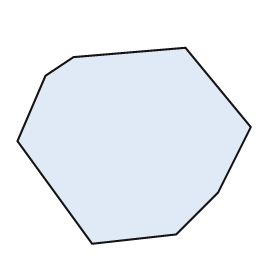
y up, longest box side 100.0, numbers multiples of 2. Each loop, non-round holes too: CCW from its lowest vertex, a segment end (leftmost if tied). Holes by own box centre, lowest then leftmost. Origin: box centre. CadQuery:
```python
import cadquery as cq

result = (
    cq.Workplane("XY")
    .moveTo(-18.0, -42.0)
    .lineTo(18.0, -38.0)
    .lineTo(36.0, -20.0)
    .lineTo(50.0, 8.0)
    .lineTo(22.0, 42.0)
    .lineTo(-26.0, 38.0)
    .lineTo(-38.0, 30.0)
    .lineTo(-50.0, 2.0)
    .close()
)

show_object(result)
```